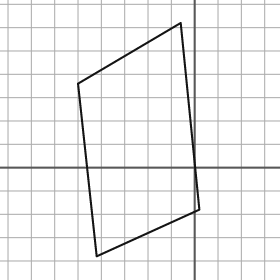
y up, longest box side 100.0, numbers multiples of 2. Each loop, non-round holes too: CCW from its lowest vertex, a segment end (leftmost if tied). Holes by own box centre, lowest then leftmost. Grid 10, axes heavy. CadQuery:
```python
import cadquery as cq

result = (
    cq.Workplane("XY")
    .moveTo(-42.0, -38.0)
    .lineTo(2.0, -18.0)
    .lineTo(-6.0, 62.0)
    .lineTo(-50.0, 36.0)
    .close()
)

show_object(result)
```